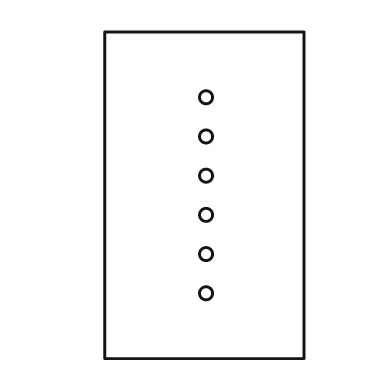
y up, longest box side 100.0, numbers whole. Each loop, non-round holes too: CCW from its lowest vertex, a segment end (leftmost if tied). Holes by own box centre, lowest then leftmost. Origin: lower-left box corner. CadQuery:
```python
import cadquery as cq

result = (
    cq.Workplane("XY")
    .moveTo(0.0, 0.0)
    .lineTo(61.0, 0.0)
    .lineTo(61.0, 100.0)
    .lineTo(0.0, 100.0)
    .close()
    .moveTo(31.0, 20.0)
    .circle(2.0)
    .moveTo(31.0, 32.0)
    .circle(2.0)
    .moveTo(31.0, 44.0)
    .circle(2.0)
    .moveTo(31.0, 56.0)
    .circle(2.0)
    .moveTo(31.0, 68.0)
    .circle(2.0)
    .moveTo(31.0, 80.0)
    .circle(2.0)
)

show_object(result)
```